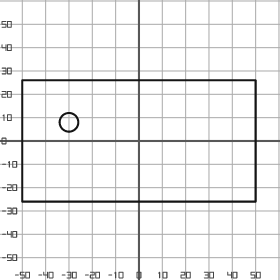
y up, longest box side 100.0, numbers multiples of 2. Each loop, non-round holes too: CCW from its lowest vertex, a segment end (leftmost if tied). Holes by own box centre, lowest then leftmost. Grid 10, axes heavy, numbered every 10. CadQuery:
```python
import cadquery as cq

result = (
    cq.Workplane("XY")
    .moveTo(-50.0, -26.0)
    .lineTo(50.0, -26.0)
    .lineTo(50.0, 26.0)
    .lineTo(-50.0, 26.0)
    .close()
    .moveTo(-30.0, 8.0)
    .circle(4.0)
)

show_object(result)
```